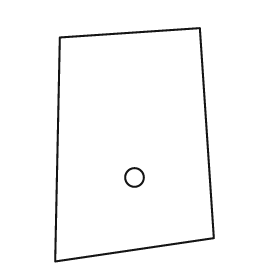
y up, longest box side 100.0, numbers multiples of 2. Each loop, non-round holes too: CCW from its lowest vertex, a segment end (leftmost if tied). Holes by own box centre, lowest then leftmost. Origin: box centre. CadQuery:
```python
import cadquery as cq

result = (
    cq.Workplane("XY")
    .moveTo(-34.0, -50.0)
    .lineTo(34.0, -40.0)
    .lineTo(28.0, 50.0)
    .lineTo(-32.0, 46.0)
    .close()
    .moveTo(0.0, -14.0)
    .circle(4.0)
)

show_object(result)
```